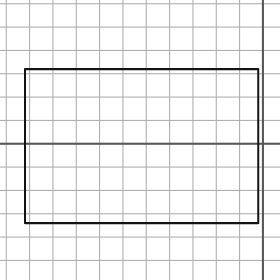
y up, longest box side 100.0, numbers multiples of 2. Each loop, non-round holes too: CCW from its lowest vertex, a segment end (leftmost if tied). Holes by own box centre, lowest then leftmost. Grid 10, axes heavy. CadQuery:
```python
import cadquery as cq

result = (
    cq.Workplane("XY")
    .moveTo(-102.0, -34.0)
    .lineTo(-2.0, -34.0)
    .lineTo(-2.0, 32.0)
    .lineTo(-102.0, 32.0)
    .close()
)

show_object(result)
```